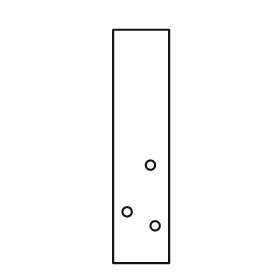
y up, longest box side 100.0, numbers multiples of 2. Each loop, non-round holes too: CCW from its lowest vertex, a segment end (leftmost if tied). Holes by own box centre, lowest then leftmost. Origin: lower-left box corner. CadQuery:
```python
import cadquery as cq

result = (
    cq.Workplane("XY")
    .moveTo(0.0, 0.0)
    .lineTo(24.0, 0.0)
    .lineTo(24.0, 100.0)
    .lineTo(0.0, 100.0)
    .close()
    .moveTo(18.0, 16.0)
    .circle(2.0)
    .moveTo(6.0, 22.0)
    .circle(2.0)
    .moveTo(16.0, 42.0)
    .circle(2.0)
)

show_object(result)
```